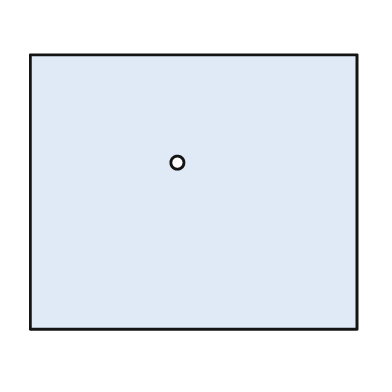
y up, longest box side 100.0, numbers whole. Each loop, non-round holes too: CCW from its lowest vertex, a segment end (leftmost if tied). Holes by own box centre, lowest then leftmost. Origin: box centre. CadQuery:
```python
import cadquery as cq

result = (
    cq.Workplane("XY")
    .moveTo(-50.0, -42.0)
    .lineTo(50.0, -42.0)
    .lineTo(50.0, 42.0)
    .lineTo(-50.0, 42.0)
    .close()
    .moveTo(-5.0, 9.0)
    .circle(2.0)
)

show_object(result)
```